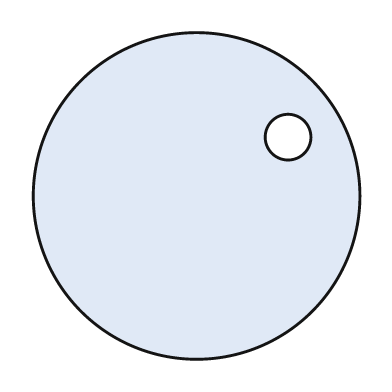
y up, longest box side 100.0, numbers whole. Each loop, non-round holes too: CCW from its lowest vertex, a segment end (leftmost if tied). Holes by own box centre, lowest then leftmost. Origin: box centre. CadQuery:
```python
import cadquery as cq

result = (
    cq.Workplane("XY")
    .moveTo(0.0, 0.0)
    .circle(50.0)
    .moveTo(28.0, 18.0)
    .circle(7.0)
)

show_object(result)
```